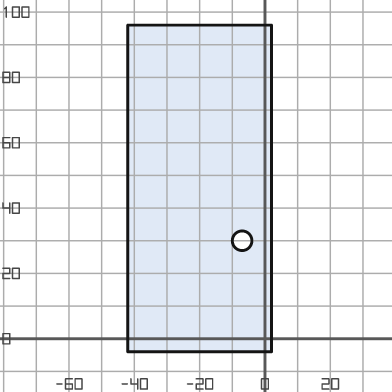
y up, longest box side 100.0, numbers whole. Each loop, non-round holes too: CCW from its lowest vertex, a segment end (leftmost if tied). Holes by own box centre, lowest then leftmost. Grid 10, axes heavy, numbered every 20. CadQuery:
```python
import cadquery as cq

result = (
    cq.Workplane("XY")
    .moveTo(-42.0, -4.0)
    .lineTo(2.0, -4.0)
    .lineTo(2.0, 96.0)
    .lineTo(-42.0, 96.0)
    .close()
    .moveTo(-7.0, 30.0)
    .circle(3.0)
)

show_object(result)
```